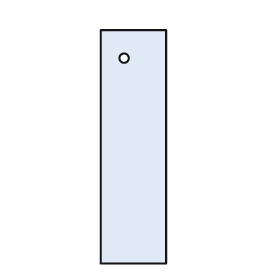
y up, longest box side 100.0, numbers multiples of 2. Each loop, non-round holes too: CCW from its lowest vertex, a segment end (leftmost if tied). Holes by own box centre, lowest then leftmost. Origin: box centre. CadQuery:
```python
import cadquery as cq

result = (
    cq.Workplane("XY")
    .moveTo(-14.0, -50.0)
    .lineTo(14.0, -50.0)
    .lineTo(14.0, 50.0)
    .lineTo(-14.0, 50.0)
    .close()
    .moveTo(-4.0, 38.0)
    .circle(2.0)
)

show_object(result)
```